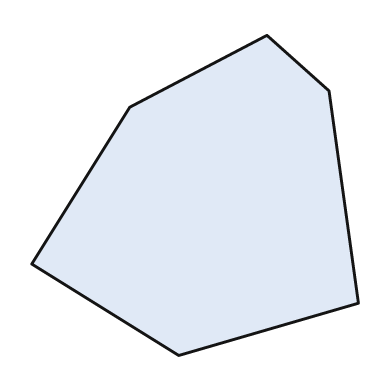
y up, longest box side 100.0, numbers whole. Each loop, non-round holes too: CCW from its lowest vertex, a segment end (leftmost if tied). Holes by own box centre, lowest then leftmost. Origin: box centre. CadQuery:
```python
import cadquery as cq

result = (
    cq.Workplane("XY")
    .moveTo(-5.0, -49.0)
    .lineTo(50.0, -33.0)
    .lineTo(41.0, 32.0)
    .lineTo(22.0, 49.0)
    .lineTo(-20.0, 27.0)
    .lineTo(-50.0, -21.0)
    .close()
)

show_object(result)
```